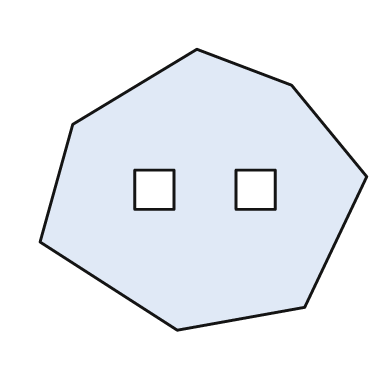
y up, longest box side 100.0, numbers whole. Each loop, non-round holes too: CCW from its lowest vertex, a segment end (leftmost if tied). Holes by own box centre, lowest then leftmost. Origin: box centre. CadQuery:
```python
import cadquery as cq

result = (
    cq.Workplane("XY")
    .moveTo(-8.0, -43.0)
    .lineTo(31.0, -36.0)
    .lineTo(50.0, 4.0)
    .lineTo(27.0, 32.0)
    .lineTo(-2.0, 43.0)
    .lineTo(-40.0, 20.0)
    .lineTo(-50.0, -16.0)
    .close()
    .moveTo(-21.0, -6.0)
    .lineTo(-9.0, -6.0)
    .lineTo(-9.0, 6.0)
    .lineTo(-21.0, 6.0)
    .close()
    .moveTo(10.0, -6.0)
    .lineTo(22.0, -6.0)
    .lineTo(22.0, 6.0)
    .lineTo(10.0, 6.0)
    .close()
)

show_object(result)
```